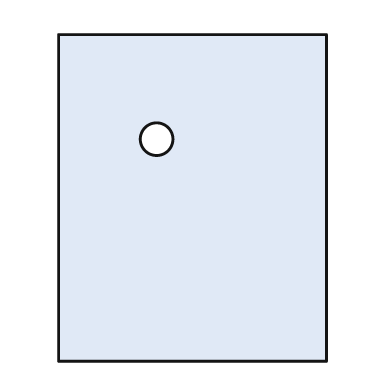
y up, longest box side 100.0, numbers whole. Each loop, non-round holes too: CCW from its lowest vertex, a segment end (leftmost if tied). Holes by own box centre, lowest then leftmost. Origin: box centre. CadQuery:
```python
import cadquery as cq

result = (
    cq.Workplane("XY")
    .moveTo(-41.0, -50.0)
    .lineTo(41.0, -50.0)
    .lineTo(41.0, 50.0)
    .lineTo(-41.0, 50.0)
    .close()
    .moveTo(-11.0, 18.0)
    .circle(5.0)
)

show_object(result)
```